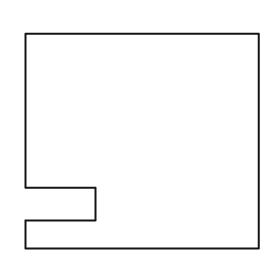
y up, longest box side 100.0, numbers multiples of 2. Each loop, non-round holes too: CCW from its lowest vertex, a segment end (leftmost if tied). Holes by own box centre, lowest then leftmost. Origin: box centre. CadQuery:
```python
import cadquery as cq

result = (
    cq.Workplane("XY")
    .moveTo(-50.0, -46.0)
    .lineTo(50.0, -46.0)
    .lineTo(50.0, 46.0)
    .lineTo(-50.0, 46.0)
    .lineTo(-50.0, -20.0)
    .lineTo(-20.0, -20.0)
    .lineTo(-20.0, -34.0)
    .lineTo(-50.0, -34.0)
    .close()
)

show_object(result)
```